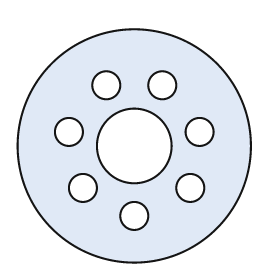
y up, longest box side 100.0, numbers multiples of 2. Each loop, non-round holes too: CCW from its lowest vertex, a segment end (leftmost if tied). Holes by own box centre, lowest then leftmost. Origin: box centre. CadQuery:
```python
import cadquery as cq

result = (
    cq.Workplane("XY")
    .moveTo(0.0, 0.0)
    .circle(50.0)
    .moveTo(0.0, -30.0)
    .circle(6.0)
    .moveTo(-22.0, -18.0)
    .circle(6.0)
    .moveTo(24.0, -18.0)
    .circle(6.0)
    .moveTo(0.0, 0.0)
    .circle(16.0)
    .moveTo(-28.0, 6.0)
    .circle(6.0)
    .moveTo(28.0, 6.0)
    .circle(6.0)
    .moveTo(-12.0, 26.0)
    .circle(6.0)
    .moveTo(12.0, 26.0)
    .circle(6.0)
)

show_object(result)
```